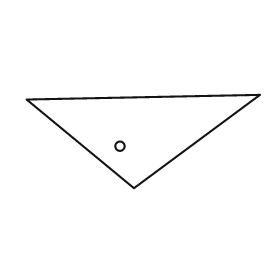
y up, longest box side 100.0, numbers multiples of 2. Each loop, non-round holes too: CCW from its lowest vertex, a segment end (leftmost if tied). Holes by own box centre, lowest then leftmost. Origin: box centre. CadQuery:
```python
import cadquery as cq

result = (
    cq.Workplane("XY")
    .moveTo(-4.0, -20.0)
    .lineTo(50.0, 20.0)
    .lineTo(-50.0, 18.0)
    .close()
    .moveTo(-10.0, -2.0)
    .circle(2.0)
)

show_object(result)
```